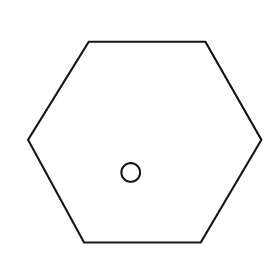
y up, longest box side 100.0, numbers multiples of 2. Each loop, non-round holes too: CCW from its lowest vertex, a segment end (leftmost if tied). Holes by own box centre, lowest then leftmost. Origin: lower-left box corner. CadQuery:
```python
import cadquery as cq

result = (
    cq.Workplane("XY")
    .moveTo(24.0, 0.0)
    .lineTo(74.0, 0.0)
    .lineTo(100.0, 44.0)
    .lineTo(76.0, 86.0)
    .lineTo(26.0, 86.0)
    .lineTo(0.0, 44.0)
    .close()
    .moveTo(44.0, 30.0)
    .circle(4.0)
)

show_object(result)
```